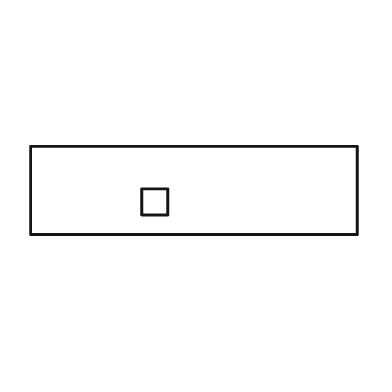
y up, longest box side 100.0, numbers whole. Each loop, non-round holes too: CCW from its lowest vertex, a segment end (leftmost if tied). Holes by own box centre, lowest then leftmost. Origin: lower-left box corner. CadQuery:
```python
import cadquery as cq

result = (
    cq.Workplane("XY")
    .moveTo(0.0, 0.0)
    .lineTo(100.0, 0.0)
    .lineTo(100.0, 27.0)
    .lineTo(0.0, 27.0)
    .close()
    .moveTo(34.0, 6.0)
    .lineTo(42.0, 6.0)
    .lineTo(42.0, 14.0)
    .lineTo(34.0, 14.0)
    .close()
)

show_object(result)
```